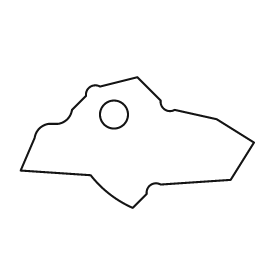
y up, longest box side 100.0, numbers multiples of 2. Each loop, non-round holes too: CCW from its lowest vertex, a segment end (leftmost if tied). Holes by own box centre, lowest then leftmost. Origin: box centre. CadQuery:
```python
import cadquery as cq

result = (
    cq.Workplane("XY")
    .moveTo(-2.0, -28.0)
    .lineTo(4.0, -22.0)
    .threePointArc((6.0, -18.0), (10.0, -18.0))
    .lineTo(40.0, -16.0)
    .lineTo(50.0, 0.0)
    .lineTo(34.0, 10.0)
    .lineTo(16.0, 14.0)
    .threePointArc((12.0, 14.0), (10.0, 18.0))
    .lineTo(0.0, 28.0)
    .lineTo(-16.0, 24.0)
    .threePointArc((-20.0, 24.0), (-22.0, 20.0))
    .lineTo(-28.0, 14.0)
    .threePointArc((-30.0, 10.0), (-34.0, 8.0))
    .lineTo(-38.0, 8.0)
    .threePointArc((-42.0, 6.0), (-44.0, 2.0))
    .lineTo(-50.0, -12.0)
    .lineTo(-20.0, -14.0)
    .threePointArc((-12.0, -22.0), (-2.0, -28.0))
    .close()
    .moveTo(-10.0, 12.0)
    .circle(6.0)
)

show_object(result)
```